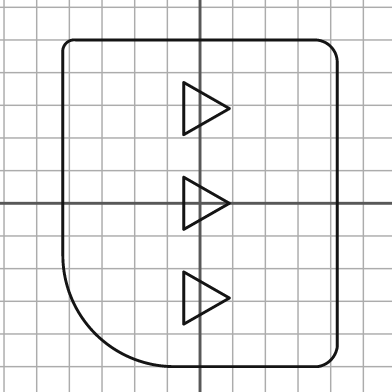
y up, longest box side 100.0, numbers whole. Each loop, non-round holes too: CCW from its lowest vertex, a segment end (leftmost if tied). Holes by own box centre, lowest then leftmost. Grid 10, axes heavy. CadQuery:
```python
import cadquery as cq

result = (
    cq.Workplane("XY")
    .moveTo(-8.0, -50.0)
    .lineTo(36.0, -50.0)
    .threePointArc((40.0, -48.0), (42.0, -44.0))
    .lineTo(42.0, 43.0)
    .threePointArc((40.0, 48.0), (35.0, 50.0))
    .lineTo(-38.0, 50.0)
    .threePointArc((-41.0, 49.0), (-42.0, 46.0))
    .lineTo(-42.0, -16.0)
    .threePointArc((-32.0, -40.0), (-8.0, -50.0))
    .close()
    .moveTo(-5.0, -37.0)
    .lineTo(9.0, -29.0)
    .lineTo(-5.0, -21.0)
    .close()
    .moveTo(-5.0, -8.0)
    .lineTo(9.0, 0.0)
    .lineTo(-5.0, 8.0)
    .close()
    .moveTo(-5.0, 21.0)
    .lineTo(9.0, 29.0)
    .lineTo(-5.0, 37.0)
    .close()
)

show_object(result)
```